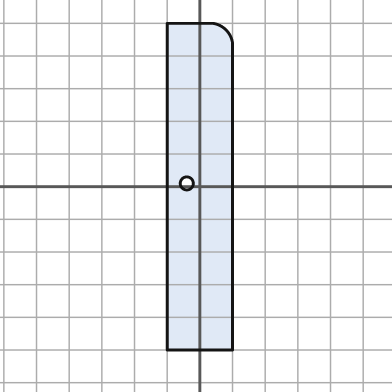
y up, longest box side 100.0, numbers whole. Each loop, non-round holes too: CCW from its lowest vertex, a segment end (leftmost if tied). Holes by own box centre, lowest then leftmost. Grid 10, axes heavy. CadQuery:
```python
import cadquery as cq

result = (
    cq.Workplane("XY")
    .moveTo(-10.0, -50.0)
    .lineTo(10.0, -50.0)
    .lineTo(10.0, 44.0)
    .threePointArc((8.0, 48.0), (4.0, 50.0))
    .lineTo(-10.0, 50.0)
    .close()
    .moveTo(-4.0, 1.0)
    .circle(2.0)
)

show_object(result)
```